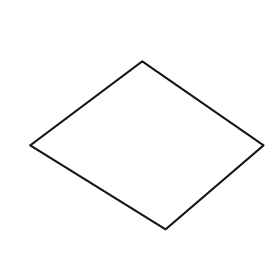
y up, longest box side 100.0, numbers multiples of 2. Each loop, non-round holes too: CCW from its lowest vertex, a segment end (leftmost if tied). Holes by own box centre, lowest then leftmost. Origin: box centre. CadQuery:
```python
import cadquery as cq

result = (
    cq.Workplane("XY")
    .moveTo(8.0, -36.0)
    .lineTo(50.0, 0.0)
    .lineTo(-2.0, 36.0)
    .lineTo(-50.0, 0.0)
    .close()
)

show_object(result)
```